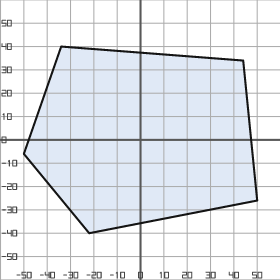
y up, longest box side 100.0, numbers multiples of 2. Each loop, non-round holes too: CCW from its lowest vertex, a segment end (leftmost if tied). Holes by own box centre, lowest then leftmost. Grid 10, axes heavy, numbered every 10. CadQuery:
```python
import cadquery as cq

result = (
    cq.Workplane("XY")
    .moveTo(-22.0, -40.0)
    .lineTo(50.0, -26.0)
    .lineTo(44.0, 34.0)
    .lineTo(-34.0, 40.0)
    .lineTo(-50.0, -6.0)
    .close()
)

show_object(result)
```